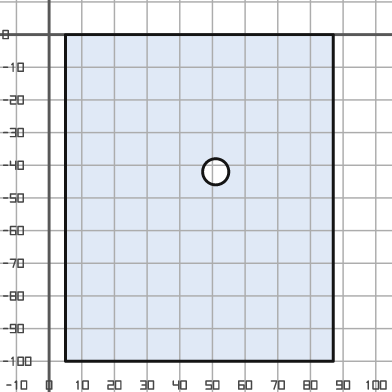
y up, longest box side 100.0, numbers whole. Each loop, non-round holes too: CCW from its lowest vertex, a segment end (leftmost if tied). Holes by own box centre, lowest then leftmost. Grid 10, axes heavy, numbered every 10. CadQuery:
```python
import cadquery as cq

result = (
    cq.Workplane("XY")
    .moveTo(5.0, -100.0)
    .lineTo(87.0, -100.0)
    .lineTo(87.0, 0.0)
    .lineTo(5.0, 0.0)
    .close()
    .moveTo(51.0, -42.0)
    .circle(4.0)
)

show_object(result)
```